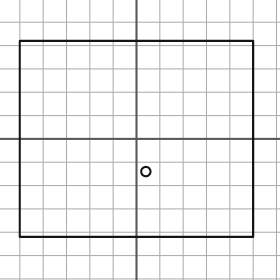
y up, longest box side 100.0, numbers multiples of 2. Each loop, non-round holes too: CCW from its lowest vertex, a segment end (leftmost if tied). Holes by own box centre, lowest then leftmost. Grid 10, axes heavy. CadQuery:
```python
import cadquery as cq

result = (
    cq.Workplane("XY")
    .moveTo(-50.0, -42.0)
    .lineTo(50.0, -42.0)
    .lineTo(50.0, 42.0)
    .lineTo(-50.0, 42.0)
    .close()
    .moveTo(4.0, -14.0)
    .circle(2.0)
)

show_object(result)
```